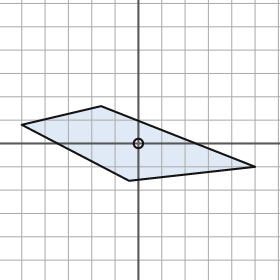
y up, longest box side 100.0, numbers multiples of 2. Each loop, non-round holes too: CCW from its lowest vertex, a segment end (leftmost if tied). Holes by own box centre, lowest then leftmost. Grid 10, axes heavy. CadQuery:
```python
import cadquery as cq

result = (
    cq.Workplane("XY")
    .moveTo(-4.0, -16.0)
    .lineTo(50.0, -10.0)
    .lineTo(-16.0, 16.0)
    .lineTo(-50.0, 8.0)
    .close()
    .moveTo(0.0, 0.0)
    .circle(2.0)
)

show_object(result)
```